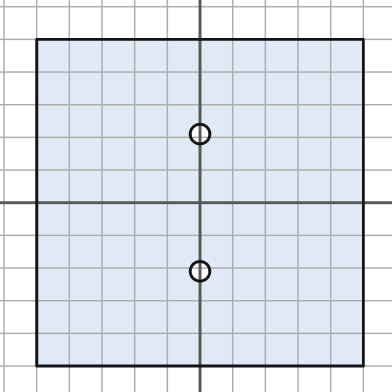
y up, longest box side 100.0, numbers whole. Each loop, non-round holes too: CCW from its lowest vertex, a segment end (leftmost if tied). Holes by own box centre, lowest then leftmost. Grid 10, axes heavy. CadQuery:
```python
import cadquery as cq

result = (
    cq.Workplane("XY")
    .moveTo(-50.0, -50.0)
    .lineTo(50.0, -50.0)
    .lineTo(50.0, 50.0)
    .lineTo(-50.0, 50.0)
    .close()
    .moveTo(0.0, -21.0)
    .circle(3.0)
    .moveTo(0.0, 21.0)
    .circle(3.0)
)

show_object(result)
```